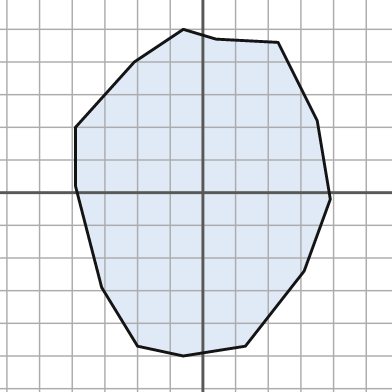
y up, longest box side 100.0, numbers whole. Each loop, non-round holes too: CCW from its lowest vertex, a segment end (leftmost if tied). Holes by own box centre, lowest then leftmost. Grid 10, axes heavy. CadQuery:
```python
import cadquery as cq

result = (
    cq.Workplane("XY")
    .moveTo(-6.0, -50.0)
    .lineTo(13.0, -47.0)
    .lineTo(31.0, -24.0)
    .lineTo(39.0, -2.0)
    .lineTo(35.0, 22.0)
    .lineTo(23.0, 46.0)
    .lineTo(4.0, 47.0)
    .lineTo(-6.0, 50.0)
    .lineTo(-21.0, 40.0)
    .lineTo(-39.0, 20.0)
    .lineTo(-39.0, 2.0)
    .lineTo(-31.0, -29.0)
    .lineTo(-20.0, -47.0)
    .close()
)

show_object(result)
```